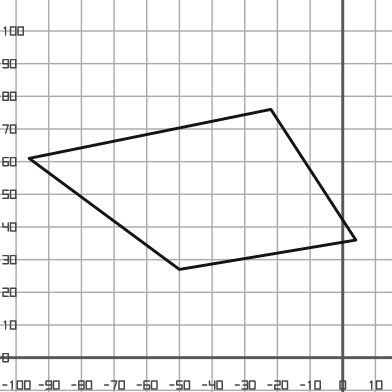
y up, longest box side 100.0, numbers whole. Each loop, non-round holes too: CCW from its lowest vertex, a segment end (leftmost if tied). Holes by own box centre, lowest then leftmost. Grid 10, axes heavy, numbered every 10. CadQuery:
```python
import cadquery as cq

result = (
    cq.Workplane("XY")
    .moveTo(-50.0, 27.0)
    .lineTo(4.0, 36.0)
    .lineTo(-22.0, 76.0)
    .lineTo(-96.0, 61.0)
    .close()
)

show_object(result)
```